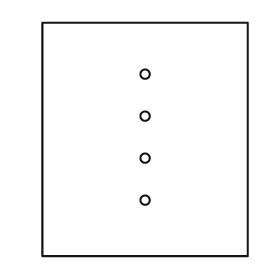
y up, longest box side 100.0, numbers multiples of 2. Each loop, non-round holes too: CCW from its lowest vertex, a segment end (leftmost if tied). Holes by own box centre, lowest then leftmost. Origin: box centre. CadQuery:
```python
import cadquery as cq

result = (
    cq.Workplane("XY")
    .moveTo(-44.0, -50.0)
    .lineTo(44.0, -50.0)
    .lineTo(44.0, 50.0)
    .lineTo(-44.0, 50.0)
    .close()
    .moveTo(0.0, -26.0)
    .circle(2.0)
    .moveTo(0.0, -8.0)
    .circle(2.0)
    .moveTo(0.0, 10.0)
    .circle(2.0)
    .moveTo(0.0, 28.0)
    .circle(2.0)
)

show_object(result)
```